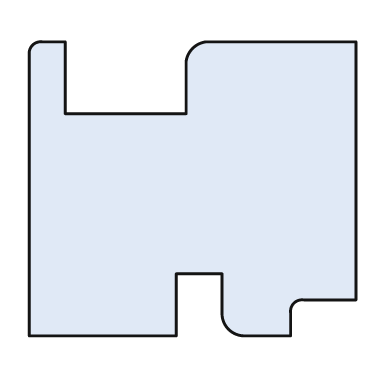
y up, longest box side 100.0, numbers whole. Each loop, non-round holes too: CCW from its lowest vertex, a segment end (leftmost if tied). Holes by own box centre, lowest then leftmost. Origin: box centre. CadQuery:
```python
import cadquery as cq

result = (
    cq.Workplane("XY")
    .moveTo(-50.0, -45.0)
    .lineTo(-5.0, -45.0)
    .lineTo(-5.0, -26.0)
    .lineTo(9.0, -26.0)
    .lineTo(9.0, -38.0)
    .threePointArc((11.0, -43.0), (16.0, -45.0))
    .lineTo(30.0, -45.0)
    .lineTo(30.0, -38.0)
    .threePointArc((31.0, -35.0), (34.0, -34.0))
    .lineTo(50.0, -34.0)
    .lineTo(50.0, 45.0)
    .lineTo(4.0, 45.0)
    .threePointArc((0.0, 43.0), (-2.0, 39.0))
    .lineTo(-2.0, 23.0)
    .lineTo(-39.0, 23.0)
    .lineTo(-39.0, 45.0)
    .lineTo(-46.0, 45.0)
    .threePointArc((-49.0, 44.0), (-50.0, 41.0))
    .close()
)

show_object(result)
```